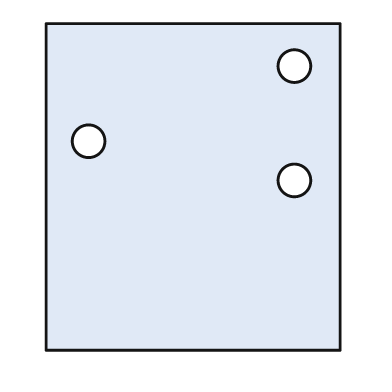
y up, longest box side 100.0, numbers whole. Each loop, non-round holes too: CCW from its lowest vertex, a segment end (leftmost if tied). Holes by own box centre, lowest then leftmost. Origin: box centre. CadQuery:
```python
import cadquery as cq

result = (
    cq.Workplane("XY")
    .moveTo(-45.0, -50.0)
    .lineTo(45.0, -50.0)
    .lineTo(45.0, 50.0)
    .lineTo(-45.0, 50.0)
    .close()
    .moveTo(31.0, 2.0)
    .circle(5.0)
    .moveTo(-32.0, 14.0)
    .circle(5.0)
    .moveTo(31.0, 37.0)
    .circle(5.0)
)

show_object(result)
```